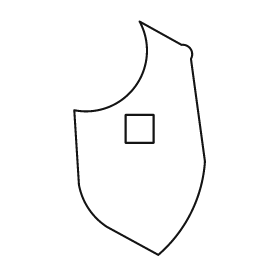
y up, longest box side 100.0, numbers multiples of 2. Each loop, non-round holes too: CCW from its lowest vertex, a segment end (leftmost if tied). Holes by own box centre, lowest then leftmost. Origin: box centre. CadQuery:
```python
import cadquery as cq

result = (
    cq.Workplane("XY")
    .moveTo(8.0, -50.0)
    .threePointArc((22.0, -32.0), (28.0, -10.0))
    .lineTo(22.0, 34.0)
    .threePointArc((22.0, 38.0), (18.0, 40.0))
    .lineTo(0.0, 50.0)
    .threePointArc((-2.0, 22.0), (-28.0, 12.0))
    .lineTo(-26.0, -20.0)
    .threePointArc((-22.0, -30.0), (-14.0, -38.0))
    .close()
    .moveTo(-6.0, -2.0)
    .lineTo(6.0, -2.0)
    .lineTo(6.0, 10.0)
    .lineTo(-6.0, 10.0)
    .close()
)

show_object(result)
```